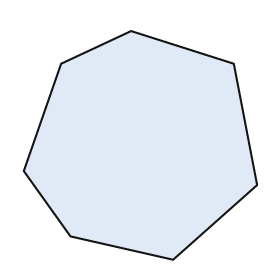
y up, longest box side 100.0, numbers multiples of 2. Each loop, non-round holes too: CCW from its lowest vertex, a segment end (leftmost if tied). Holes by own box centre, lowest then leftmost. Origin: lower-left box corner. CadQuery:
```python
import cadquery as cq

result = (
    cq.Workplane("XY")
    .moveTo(64.0, 0.0)
    .lineTo(100.0, 32.0)
    .lineTo(90.0, 84.0)
    .lineTo(46.0, 98.0)
    .lineTo(16.0, 84.0)
    .lineTo(0.0, 38.0)
    .lineTo(20.0, 10.0)
    .close()
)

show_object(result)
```